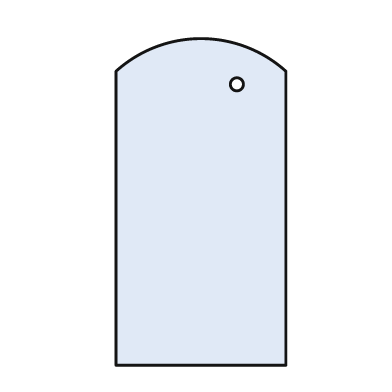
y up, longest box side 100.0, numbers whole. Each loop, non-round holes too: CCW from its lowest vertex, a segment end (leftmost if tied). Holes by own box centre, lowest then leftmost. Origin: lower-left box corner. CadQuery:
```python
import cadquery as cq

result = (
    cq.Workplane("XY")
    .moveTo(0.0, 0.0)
    .lineTo(52.0, 0.0)
    .lineTo(52.0, 90.0)
    .threePointArc((26.0, 100.0), (0.0, 90.0))
    .close()
    .moveTo(37.0, 86.0)
    .circle(2.0)
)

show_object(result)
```